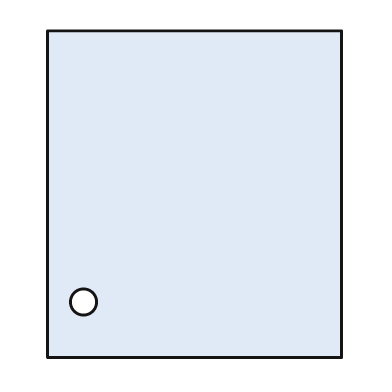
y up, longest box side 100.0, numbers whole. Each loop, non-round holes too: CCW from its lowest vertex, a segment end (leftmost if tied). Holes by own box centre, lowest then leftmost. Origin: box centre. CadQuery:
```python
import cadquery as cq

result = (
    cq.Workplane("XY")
    .moveTo(-45.0, -50.0)
    .lineTo(45.0, -50.0)
    .lineTo(45.0, 50.0)
    .lineTo(-45.0, 50.0)
    .close()
    .moveTo(-34.0, -33.0)
    .circle(4.0)
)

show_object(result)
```